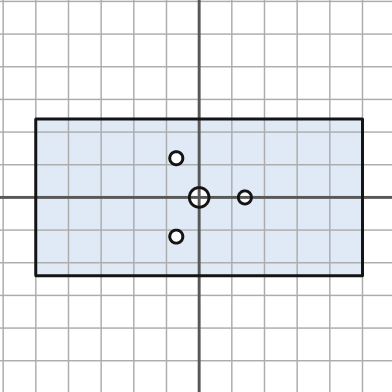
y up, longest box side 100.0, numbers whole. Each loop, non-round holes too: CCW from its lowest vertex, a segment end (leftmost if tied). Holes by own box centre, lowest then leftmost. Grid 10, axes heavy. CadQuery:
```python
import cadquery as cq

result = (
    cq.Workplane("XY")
    .moveTo(-50.0, -24.0)
    .lineTo(50.0, -24.0)
    .lineTo(50.0, 24.0)
    .lineTo(-50.0, 24.0)
    .close()
    .moveTo(-7.0, -12.0)
    .circle(2.0)
    .moveTo(0.0, 0.0)
    .circle(3.0)
    .moveTo(14.0, 0.0)
    .circle(2.0)
    .moveTo(-7.0, 12.0)
    .circle(2.0)
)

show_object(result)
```